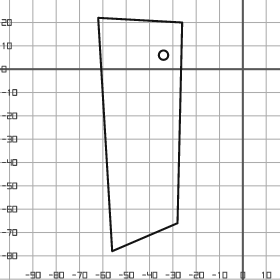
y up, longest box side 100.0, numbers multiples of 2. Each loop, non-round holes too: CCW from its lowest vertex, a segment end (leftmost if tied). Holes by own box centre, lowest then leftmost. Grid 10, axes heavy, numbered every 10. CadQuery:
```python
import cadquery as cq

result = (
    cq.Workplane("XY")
    .moveTo(-56.0, -78.0)
    .lineTo(-28.0, -66.0)
    .lineTo(-26.0, 20.0)
    .lineTo(-62.0, 22.0)
    .close()
    .moveTo(-34.0, 6.0)
    .circle(2.0)
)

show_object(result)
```